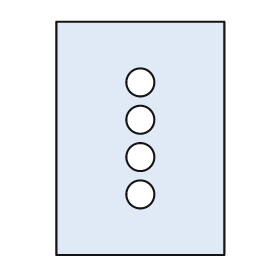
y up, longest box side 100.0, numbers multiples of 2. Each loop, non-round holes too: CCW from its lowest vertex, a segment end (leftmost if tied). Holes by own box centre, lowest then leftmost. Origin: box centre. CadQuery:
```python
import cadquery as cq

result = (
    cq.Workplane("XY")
    .moveTo(-36.0, -50.0)
    .lineTo(36.0, -50.0)
    .lineTo(36.0, 50.0)
    .lineTo(-36.0, 50.0)
    .close()
    .moveTo(0.0, -24.0)
    .circle(6.0)
    .moveTo(0.0, -8.0)
    .circle(6.0)
    .moveTo(0.0, 8.0)
    .circle(6.0)
    .moveTo(0.0, 24.0)
    .circle(6.0)
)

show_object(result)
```